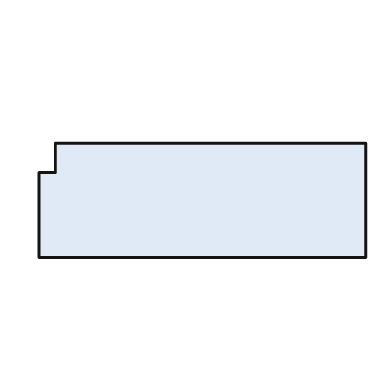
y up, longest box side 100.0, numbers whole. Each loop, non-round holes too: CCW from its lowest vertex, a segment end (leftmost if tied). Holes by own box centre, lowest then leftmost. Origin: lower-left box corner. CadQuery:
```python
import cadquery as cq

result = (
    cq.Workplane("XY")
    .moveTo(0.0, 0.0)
    .lineTo(100.0, 0.0)
    .lineTo(100.0, 35.0)
    .lineTo(5.0, 35.0)
    .lineTo(5.0, 26.0)
    .lineTo(0.0, 26.0)
    .close()
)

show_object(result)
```